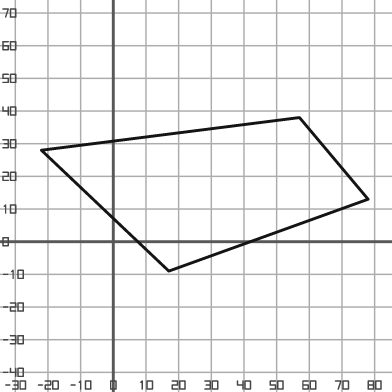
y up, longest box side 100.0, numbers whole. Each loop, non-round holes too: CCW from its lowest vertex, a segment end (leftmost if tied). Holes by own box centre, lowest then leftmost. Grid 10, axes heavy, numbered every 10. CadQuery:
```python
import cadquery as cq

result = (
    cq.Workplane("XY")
    .moveTo(17.0, -9.0)
    .lineTo(78.0, 13.0)
    .lineTo(57.0, 38.0)
    .lineTo(-22.0, 28.0)
    .close()
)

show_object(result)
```